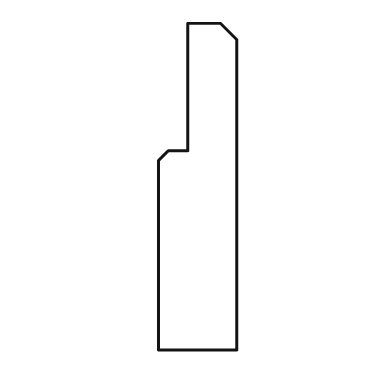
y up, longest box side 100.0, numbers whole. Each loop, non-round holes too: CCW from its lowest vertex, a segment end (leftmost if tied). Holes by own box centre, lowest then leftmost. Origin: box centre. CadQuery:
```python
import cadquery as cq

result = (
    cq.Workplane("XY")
    .moveTo(-12.0, -50.0)
    .lineTo(12.0, -50.0)
    .lineTo(12.0, 45.0)
    .lineTo(7.0, 50.0)
    .lineTo(-3.0, 50.0)
    .lineTo(-3.0, 11.0)
    .lineTo(-9.0, 11.0)
    .lineTo(-12.0, 8.0)
    .close()
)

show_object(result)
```